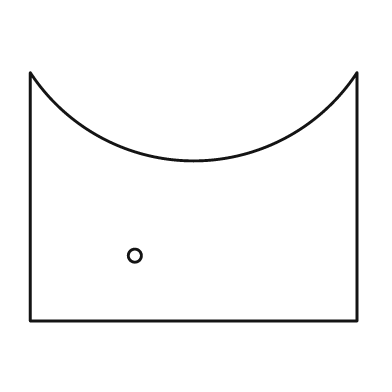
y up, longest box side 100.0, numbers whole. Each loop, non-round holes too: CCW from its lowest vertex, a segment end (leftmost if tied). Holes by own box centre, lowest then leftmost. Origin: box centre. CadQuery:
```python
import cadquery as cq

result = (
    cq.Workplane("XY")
    .moveTo(-50.0, -38.0)
    .lineTo(50.0, -38.0)
    .lineTo(50.0, 38.0)
    .threePointArc((0.0, 11.0), (-50.0, 38.0))
    .close()
    .moveTo(-18.0, -18.0)
    .circle(2.0)
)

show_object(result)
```